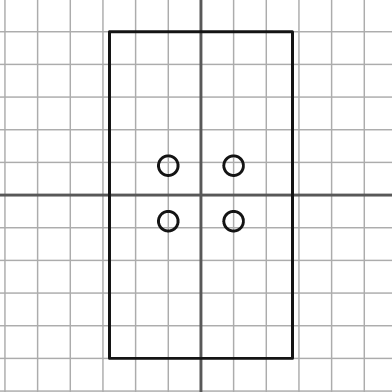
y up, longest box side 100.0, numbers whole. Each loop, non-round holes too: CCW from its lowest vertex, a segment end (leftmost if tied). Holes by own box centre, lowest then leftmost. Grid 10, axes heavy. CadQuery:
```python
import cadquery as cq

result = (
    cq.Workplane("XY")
    .moveTo(-28.0, -50.0)
    .lineTo(28.0, -50.0)
    .lineTo(28.0, 50.0)
    .lineTo(-28.0, 50.0)
    .close()
    .moveTo(-10.0, -8.0)
    .circle(3.0)
    .moveTo(10.0, -8.0)
    .circle(3.0)
    .moveTo(-10.0, 9.0)
    .circle(3.0)
    .moveTo(10.0, 9.0)
    .circle(3.0)
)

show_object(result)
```